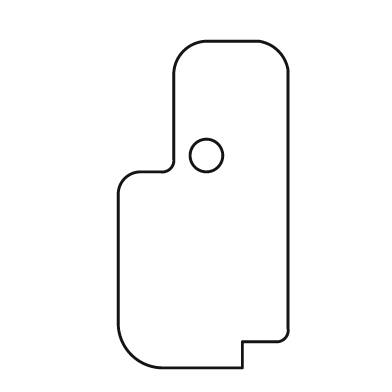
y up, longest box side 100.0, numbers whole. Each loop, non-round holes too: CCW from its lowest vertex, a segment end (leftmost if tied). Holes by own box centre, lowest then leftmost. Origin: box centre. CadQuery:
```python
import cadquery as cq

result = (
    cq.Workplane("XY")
    .moveTo(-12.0, -50.0)
    .lineTo(12.0, -50.0)
    .lineTo(12.0, -42.0)
    .lineTo(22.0, -42.0)
    .threePointArc((25.0, -41.0), (26.0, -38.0))
    .lineTo(26.0, 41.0)
    .threePointArc((23.0, 47.0), (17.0, 50.0))
    .lineTo(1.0, 50.0)
    .threePointArc((-6.0, 47.0), (-9.0, 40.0))
    .lineTo(-9.0, 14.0)
    .threePointArc((-10.0, 11.0), (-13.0, 10.0))
    .lineTo(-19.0, 10.0)
    .threePointArc((-24.0, 8.0), (-26.0, 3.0))
    .lineTo(-26.0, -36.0)
    .threePointArc((-22.0, -46.0), (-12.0, -50.0))
    .close()
    .moveTo(1.0, 15.0)
    .circle(5.0)
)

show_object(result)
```